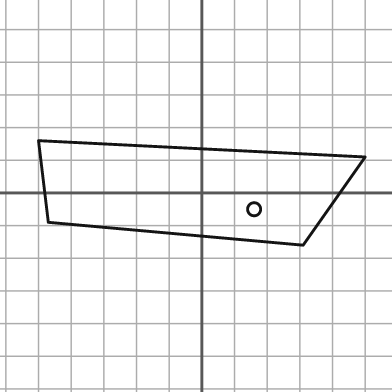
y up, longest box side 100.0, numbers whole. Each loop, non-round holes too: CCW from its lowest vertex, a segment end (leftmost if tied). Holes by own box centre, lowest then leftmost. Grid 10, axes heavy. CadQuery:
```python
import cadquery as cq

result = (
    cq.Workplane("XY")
    .moveTo(31.0, -16.0)
    .lineTo(50.0, 11.0)
    .lineTo(-50.0, 16.0)
    .lineTo(-47.0, -9.0)
    .close()
    .moveTo(16.0, -5.0)
    .circle(2.0)
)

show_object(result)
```